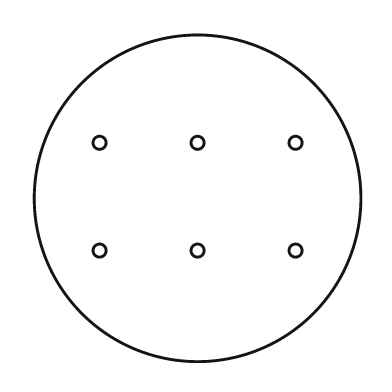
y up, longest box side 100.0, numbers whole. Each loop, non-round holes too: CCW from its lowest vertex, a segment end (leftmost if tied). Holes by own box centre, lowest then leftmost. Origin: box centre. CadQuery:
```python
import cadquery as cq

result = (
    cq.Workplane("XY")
    .moveTo(0.0, 0.0)
    .circle(50.0)
    .moveTo(-30.0, -16.0)
    .circle(2.0)
    .moveTo(0.0, -16.0)
    .circle(2.0)
    .moveTo(30.0, -16.0)
    .circle(2.0)
    .moveTo(-30.0, 17.0)
    .circle(2.0)
    .moveTo(0.0, 17.0)
    .circle(2.0)
    .moveTo(30.0, 17.0)
    .circle(2.0)
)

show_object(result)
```